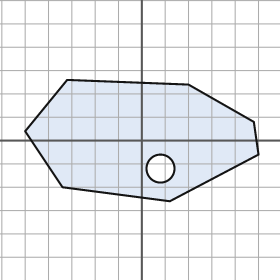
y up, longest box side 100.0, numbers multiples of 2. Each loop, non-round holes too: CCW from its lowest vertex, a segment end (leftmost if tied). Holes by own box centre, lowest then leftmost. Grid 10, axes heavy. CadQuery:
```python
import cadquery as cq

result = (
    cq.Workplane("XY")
    .moveTo(12.0, -26.0)
    .lineTo(50.0, -6.0)
    .lineTo(48.0, 8.0)
    .lineTo(20.0, 24.0)
    .lineTo(-32.0, 26.0)
    .lineTo(-50.0, 4.0)
    .lineTo(-34.0, -20.0)
    .close()
    .moveTo(8.0, -12.0)
    .circle(6.0)
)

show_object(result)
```